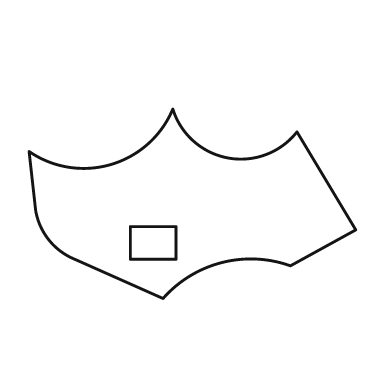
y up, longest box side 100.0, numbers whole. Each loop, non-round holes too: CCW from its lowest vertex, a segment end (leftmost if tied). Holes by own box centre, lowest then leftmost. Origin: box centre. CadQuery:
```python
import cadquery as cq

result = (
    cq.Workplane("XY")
    .moveTo(-9.0, -29.0)
    .threePointArc((9.0, -18.0), (30.0, -19.0))
    .lineTo(50.0, -8.0)
    .lineTo(32.0, 22.0)
    .threePointArc((11.0, 14.0), (-6.0, 29.0))
    .threePointArc((-25.0, 12.0), (-50.0, 16.0))
    .lineTo(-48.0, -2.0)
    .threePointArc((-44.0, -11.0), (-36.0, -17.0))
    .close()
    .moveTo(-19.0, -17.0)
    .lineTo(-5.0, -17.0)
    .lineTo(-5.0, -7.0)
    .lineTo(-19.0, -7.0)
    .close()
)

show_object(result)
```